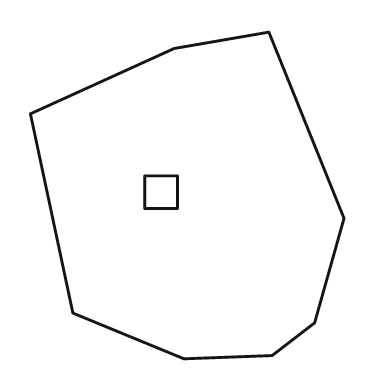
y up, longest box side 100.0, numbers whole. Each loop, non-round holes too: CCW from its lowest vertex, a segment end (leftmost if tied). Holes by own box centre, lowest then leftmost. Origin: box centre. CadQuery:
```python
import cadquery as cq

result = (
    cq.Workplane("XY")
    .moveTo(-1.0, -50.0)
    .lineTo(26.0, -49.0)
    .lineTo(39.0, -39.0)
    .lineTo(48.0, -7.0)
    .lineTo(25.0, 50.0)
    .lineTo(-4.0, 45.0)
    .lineTo(-48.0, 25.0)
    .lineTo(-35.0, -36.0)
    .close()
    .moveTo(-13.0, -4.0)
    .lineTo(-3.0, -4.0)
    .lineTo(-3.0, 6.0)
    .lineTo(-13.0, 6.0)
    .close()
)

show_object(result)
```